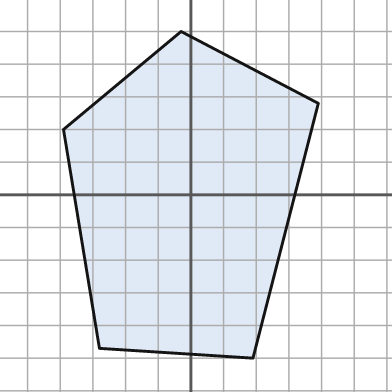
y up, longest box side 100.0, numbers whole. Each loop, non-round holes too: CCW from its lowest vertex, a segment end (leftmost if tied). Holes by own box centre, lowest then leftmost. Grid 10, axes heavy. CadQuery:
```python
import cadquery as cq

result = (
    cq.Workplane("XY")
    .moveTo(19.0, -50.0)
    .lineTo(39.0, 28.0)
    .lineTo(-3.0, 50.0)
    .lineTo(-39.0, 20.0)
    .lineTo(-28.0, -47.0)
    .close()
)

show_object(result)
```